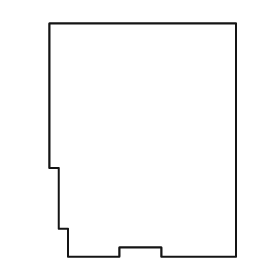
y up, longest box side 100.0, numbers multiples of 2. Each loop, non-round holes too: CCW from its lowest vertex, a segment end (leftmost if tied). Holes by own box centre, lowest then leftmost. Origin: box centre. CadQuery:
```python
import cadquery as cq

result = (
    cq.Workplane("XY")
    .moveTo(-32.0, -50.0)
    .lineTo(-10.0, -50.0)
    .lineTo(-10.0, -46.0)
    .lineTo(8.0, -46.0)
    .lineTo(8.0, -50.0)
    .lineTo(40.0, -50.0)
    .lineTo(40.0, 50.0)
    .lineTo(-40.0, 50.0)
    .lineTo(-40.0, -12.0)
    .lineTo(-36.0, -12.0)
    .lineTo(-36.0, -38.0)
    .lineTo(-32.0, -38.0)
    .close()
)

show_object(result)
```